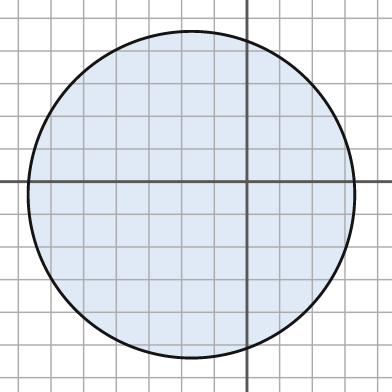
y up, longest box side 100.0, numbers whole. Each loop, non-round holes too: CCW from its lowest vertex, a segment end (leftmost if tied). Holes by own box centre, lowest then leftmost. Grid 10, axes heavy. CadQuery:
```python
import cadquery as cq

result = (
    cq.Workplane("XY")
    .moveTo(-17.0, -4.0)
    .circle(50.0)
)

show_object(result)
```